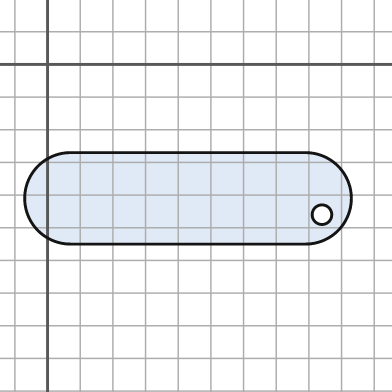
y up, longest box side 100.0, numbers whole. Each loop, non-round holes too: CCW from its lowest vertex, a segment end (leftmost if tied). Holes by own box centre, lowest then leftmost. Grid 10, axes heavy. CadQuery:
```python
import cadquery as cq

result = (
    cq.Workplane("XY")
    .moveTo(7.0, -55.0)
    .lineTo(79.0, -55.0)
    .threePointArc((93.0, -41.0), (79.0, -27.0))
    .lineTo(7.0, -27.0)
    .threePointArc((-7.0, -41.0), (7.0, -55.0))
    .close()
    .moveTo(84.0, -46.0)
    .circle(3.0)
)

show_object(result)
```